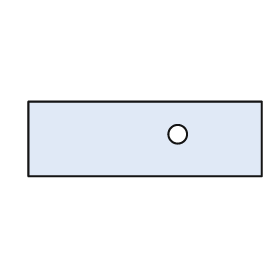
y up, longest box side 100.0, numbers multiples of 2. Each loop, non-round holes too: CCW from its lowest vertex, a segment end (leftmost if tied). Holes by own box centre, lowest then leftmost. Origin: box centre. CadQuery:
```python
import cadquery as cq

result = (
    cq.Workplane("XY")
    .moveTo(-50.0, -16.0)
    .lineTo(50.0, -16.0)
    .lineTo(50.0, 16.0)
    .lineTo(-50.0, 16.0)
    .close()
    .moveTo(14.0, 2.0)
    .circle(4.0)
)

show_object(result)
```